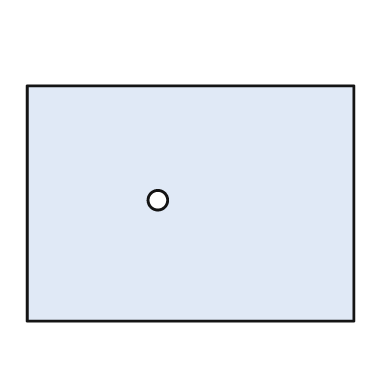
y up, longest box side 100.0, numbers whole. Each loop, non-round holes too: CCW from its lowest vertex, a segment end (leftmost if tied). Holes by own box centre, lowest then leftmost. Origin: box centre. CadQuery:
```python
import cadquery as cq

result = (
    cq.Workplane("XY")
    .moveTo(-50.0, -36.0)
    .lineTo(50.0, -36.0)
    .lineTo(50.0, 36.0)
    .lineTo(-50.0, 36.0)
    .close()
    .moveTo(-10.0, 1.0)
    .circle(3.0)
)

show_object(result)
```